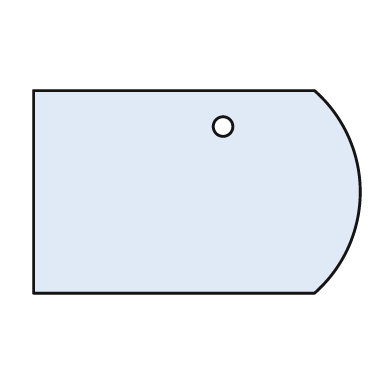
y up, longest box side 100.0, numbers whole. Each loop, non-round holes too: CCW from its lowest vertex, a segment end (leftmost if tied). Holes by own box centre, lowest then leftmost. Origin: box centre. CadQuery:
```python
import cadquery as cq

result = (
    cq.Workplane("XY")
    .moveTo(-50.0, -31.0)
    .lineTo(36.0, -31.0)
    .threePointArc((50.0, 0.0), (36.0, 31.0))
    .lineTo(-50.0, 31.0)
    .close()
    .moveTo(8.0, 20.0)
    .circle(3.0)
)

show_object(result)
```